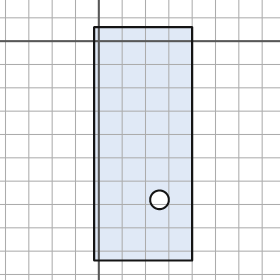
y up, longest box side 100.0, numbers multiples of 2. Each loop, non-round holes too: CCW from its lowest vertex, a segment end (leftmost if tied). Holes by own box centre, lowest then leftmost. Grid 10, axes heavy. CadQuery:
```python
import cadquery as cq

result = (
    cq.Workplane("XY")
    .moveTo(-2.0, -94.0)
    .lineTo(40.0, -94.0)
    .lineTo(40.0, 6.0)
    .lineTo(-2.0, 6.0)
    .close()
    .moveTo(26.0, -68.0)
    .circle(4.0)
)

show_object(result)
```